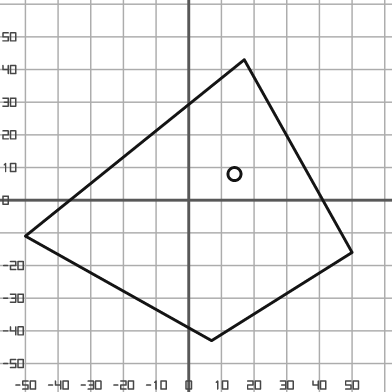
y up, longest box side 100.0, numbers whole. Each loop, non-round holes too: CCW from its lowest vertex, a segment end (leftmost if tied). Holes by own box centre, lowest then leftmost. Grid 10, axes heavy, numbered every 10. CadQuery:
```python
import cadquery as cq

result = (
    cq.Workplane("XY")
    .moveTo(7.0, -43.0)
    .lineTo(50.0, -16.0)
    .lineTo(17.0, 43.0)
    .lineTo(-50.0, -11.0)
    .close()
    .moveTo(14.0, 8.0)
    .circle(2.0)
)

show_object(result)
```